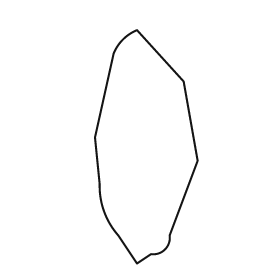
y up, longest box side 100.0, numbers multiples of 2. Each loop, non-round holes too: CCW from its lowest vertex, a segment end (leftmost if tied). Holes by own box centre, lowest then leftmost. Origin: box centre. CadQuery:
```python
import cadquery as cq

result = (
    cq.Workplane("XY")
    .moveTo(-4.0, -50.0)
    .lineTo(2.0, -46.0)
    .threePointArc((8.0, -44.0), (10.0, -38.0))
    .lineTo(22.0, -6.0)
    .lineTo(16.0, 28.0)
    .lineTo(-4.0, 50.0)
    .threePointArc((-10.0, 46.0), (-14.0, 40.0))
    .lineTo(-22.0, 4.0)
    .lineTo(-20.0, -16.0)
    .threePointArc((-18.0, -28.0), (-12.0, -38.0))
    .close()
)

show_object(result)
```